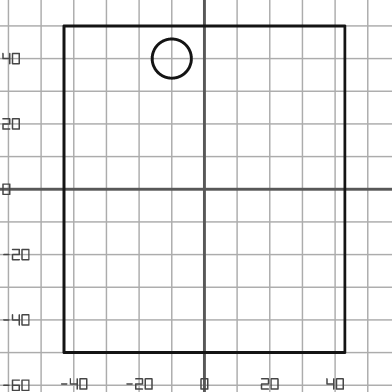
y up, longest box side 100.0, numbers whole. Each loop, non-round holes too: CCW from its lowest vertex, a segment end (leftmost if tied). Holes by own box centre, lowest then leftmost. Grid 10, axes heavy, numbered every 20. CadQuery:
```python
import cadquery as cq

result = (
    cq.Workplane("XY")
    .moveTo(-43.0, -50.0)
    .lineTo(43.0, -50.0)
    .lineTo(43.0, 50.0)
    .lineTo(-43.0, 50.0)
    .close()
    .moveTo(-10.0, 40.0)
    .circle(6.0)
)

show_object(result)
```